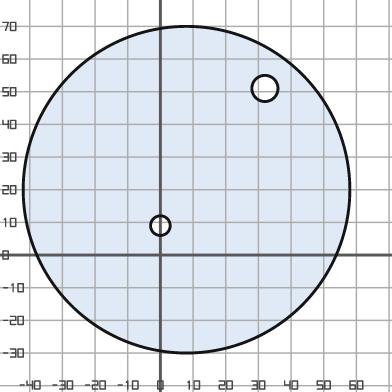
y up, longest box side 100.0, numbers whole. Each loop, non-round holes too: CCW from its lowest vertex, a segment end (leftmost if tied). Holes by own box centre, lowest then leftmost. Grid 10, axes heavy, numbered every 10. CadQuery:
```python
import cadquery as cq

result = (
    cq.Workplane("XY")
    .moveTo(8.0, 20.0)
    .circle(50.0)
    .moveTo(0.0, 9.0)
    .circle(3.0)
    .moveTo(32.0, 51.0)
    .circle(4.0)
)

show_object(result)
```